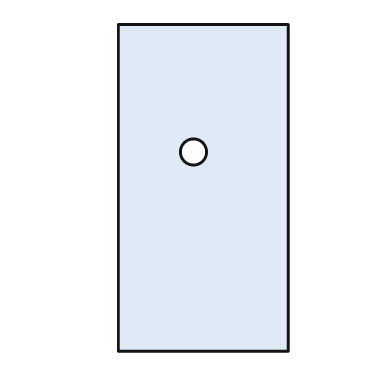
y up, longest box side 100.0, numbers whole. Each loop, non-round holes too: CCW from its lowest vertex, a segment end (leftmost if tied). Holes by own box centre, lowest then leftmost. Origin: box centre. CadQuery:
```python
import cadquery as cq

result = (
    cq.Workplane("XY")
    .moveTo(-26.0, -50.0)
    .lineTo(26.0, -50.0)
    .lineTo(26.0, 50.0)
    .lineTo(-26.0, 50.0)
    .close()
    .moveTo(-3.0, 11.0)
    .circle(4.0)
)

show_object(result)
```